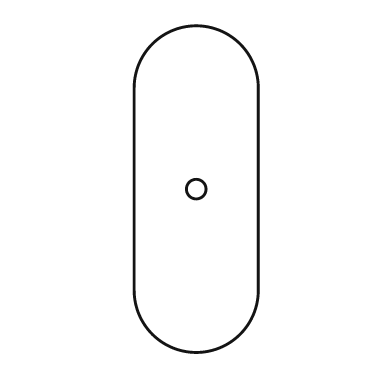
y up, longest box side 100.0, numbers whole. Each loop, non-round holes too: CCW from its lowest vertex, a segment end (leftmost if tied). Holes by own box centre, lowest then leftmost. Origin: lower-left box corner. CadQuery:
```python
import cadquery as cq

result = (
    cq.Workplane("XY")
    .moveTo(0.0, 19.0)
    .threePointArc((19.0, 0.0), (38.0, 19.0))
    .lineTo(38.0, 81.0)
    .threePointArc((19.0, 100.0), (0.0, 81.0))
    .close()
    .moveTo(19.0, 50.0)
    .circle(3.0)
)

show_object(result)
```